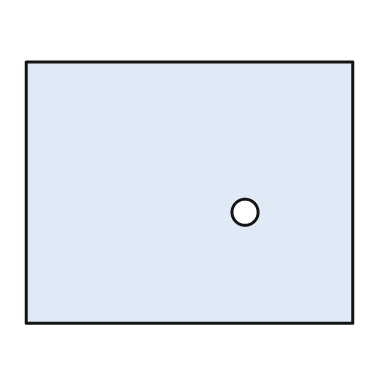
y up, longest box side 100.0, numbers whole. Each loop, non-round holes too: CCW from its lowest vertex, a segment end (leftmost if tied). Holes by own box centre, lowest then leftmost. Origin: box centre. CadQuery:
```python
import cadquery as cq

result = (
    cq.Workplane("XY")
    .moveTo(-50.0, -40.0)
    .lineTo(50.0, -40.0)
    .lineTo(50.0, 40.0)
    .lineTo(-50.0, 40.0)
    .close()
    .moveTo(17.0, -6.0)
    .circle(4.0)
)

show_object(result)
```